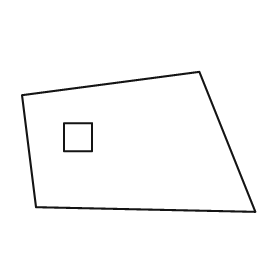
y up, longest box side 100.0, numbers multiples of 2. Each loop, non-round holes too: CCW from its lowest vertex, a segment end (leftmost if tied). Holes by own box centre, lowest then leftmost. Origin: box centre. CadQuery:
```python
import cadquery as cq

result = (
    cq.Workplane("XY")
    .moveTo(50.0, -30.0)
    .lineTo(26.0, 30.0)
    .lineTo(-50.0, 20.0)
    .lineTo(-44.0, -28.0)
    .close()
    .moveTo(-32.0, -4.0)
    .lineTo(-20.0, -4.0)
    .lineTo(-20.0, 8.0)
    .lineTo(-32.0, 8.0)
    .close()
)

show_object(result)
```